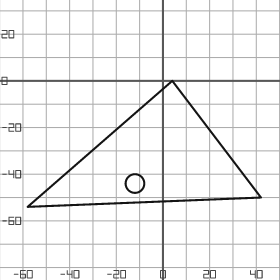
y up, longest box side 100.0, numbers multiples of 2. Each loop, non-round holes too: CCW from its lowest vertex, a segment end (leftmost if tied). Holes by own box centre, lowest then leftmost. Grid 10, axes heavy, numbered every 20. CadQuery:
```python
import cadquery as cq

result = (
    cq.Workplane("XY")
    .moveTo(-58.0, -54.0)
    .lineTo(42.0, -50.0)
    .lineTo(4.0, 0.0)
    .close()
    .moveTo(-12.0, -44.0)
    .circle(4.0)
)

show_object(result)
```